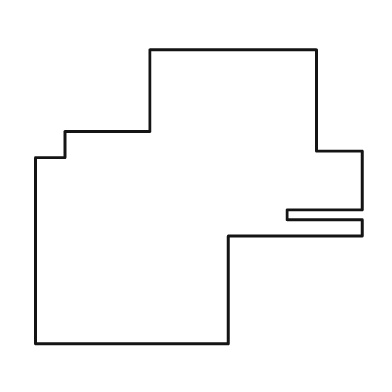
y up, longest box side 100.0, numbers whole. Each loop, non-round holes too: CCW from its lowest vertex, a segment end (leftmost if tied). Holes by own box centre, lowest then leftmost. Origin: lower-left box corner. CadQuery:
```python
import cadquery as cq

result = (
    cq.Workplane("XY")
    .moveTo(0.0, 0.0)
    .lineTo(59.0, 0.0)
    .lineTo(59.0, 33.0)
    .lineTo(100.0, 33.0)
    .lineTo(100.0, 38.0)
    .lineTo(77.0, 38.0)
    .lineTo(77.0, 41.0)
    .lineTo(100.0, 41.0)
    .lineTo(100.0, 59.0)
    .lineTo(86.0, 59.0)
    .lineTo(86.0, 90.0)
    .lineTo(35.0, 90.0)
    .lineTo(35.0, 65.0)
    .lineTo(9.0, 65.0)
    .lineTo(9.0, 57.0)
    .lineTo(0.0, 57.0)
    .close()
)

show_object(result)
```